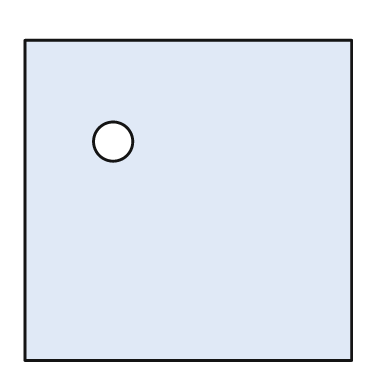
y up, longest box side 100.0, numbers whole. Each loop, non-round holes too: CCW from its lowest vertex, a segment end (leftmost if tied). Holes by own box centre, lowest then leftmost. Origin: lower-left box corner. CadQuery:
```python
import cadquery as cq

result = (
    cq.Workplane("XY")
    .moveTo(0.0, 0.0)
    .lineTo(100.0, 0.0)
    .lineTo(100.0, 98.0)
    .lineTo(0.0, 98.0)
    .close()
    .moveTo(27.0, 67.0)
    .circle(6.0)
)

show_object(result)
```